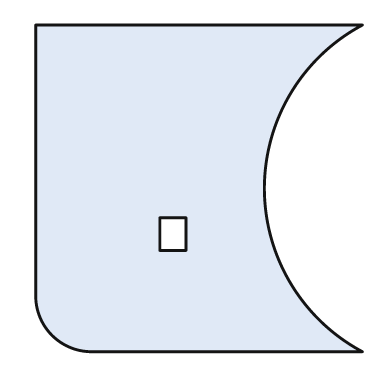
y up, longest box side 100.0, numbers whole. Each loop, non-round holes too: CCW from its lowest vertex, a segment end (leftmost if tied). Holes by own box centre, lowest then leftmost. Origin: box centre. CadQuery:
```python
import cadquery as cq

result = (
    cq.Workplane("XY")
    .moveTo(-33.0, -50.0)
    .lineTo(50.0, -50.0)
    .threePointArc((20.0, 0.0), (50.0, 50.0))
    .lineTo(-50.0, 50.0)
    .lineTo(-50.0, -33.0)
    .threePointArc((-45.0, -45.0), (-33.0, -50.0))
    .close()
    .moveTo(-12.0, -19.0)
    .lineTo(-4.0, -19.0)
    .lineTo(-4.0, -9.0)
    .lineTo(-12.0, -9.0)
    .close()
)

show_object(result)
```